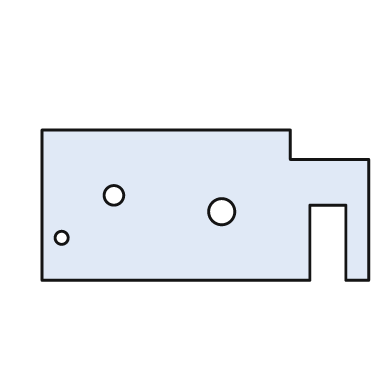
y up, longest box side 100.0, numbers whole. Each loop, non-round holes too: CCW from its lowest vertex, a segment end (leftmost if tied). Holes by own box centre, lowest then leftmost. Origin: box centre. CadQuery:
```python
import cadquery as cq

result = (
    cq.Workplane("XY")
    .moveTo(-50.0, -23.0)
    .lineTo(32.0, -23.0)
    .lineTo(32.0, 0.0)
    .lineTo(43.0, 0.0)
    .lineTo(43.0, -23.0)
    .lineTo(50.0, -23.0)
    .lineTo(50.0, 14.0)
    .lineTo(26.0, 14.0)
    .lineTo(26.0, 23.0)
    .lineTo(-50.0, 23.0)
    .close()
    .moveTo(-44.0, -10.0)
    .circle(2.0)
    .moveTo(5.0, -2.0)
    .circle(4.0)
    .moveTo(-28.0, 3.0)
    .circle(3.0)
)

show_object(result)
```